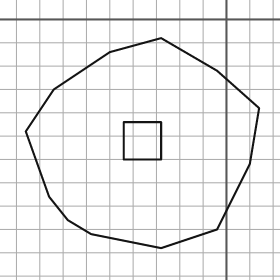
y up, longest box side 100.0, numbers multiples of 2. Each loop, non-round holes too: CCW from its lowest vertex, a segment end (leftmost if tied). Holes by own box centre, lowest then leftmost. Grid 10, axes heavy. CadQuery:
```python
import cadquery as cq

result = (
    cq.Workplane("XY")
    .moveTo(-28.0, -98.0)
    .lineTo(-4.0, -90.0)
    .lineTo(10.0, -62.0)
    .lineTo(14.0, -38.0)
    .lineTo(-4.0, -22.0)
    .lineTo(-28.0, -8.0)
    .lineTo(-50.0, -14.0)
    .lineTo(-74.0, -30.0)
    .lineTo(-86.0, -48.0)
    .lineTo(-76.0, -76.0)
    .lineTo(-68.0, -86.0)
    .lineTo(-58.0, -92.0)
    .close()
    .moveTo(-44.0, -60.0)
    .lineTo(-28.0, -60.0)
    .lineTo(-28.0, -44.0)
    .lineTo(-44.0, -44.0)
    .close()
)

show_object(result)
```